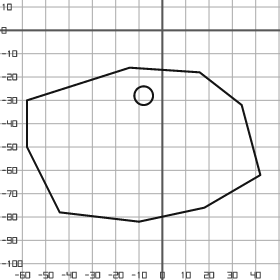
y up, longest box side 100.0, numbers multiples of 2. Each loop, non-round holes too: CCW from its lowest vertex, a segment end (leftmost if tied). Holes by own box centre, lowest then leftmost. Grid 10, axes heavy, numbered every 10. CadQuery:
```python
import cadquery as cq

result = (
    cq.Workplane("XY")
    .moveTo(-10.0, -82.0)
    .lineTo(18.0, -76.0)
    .lineTo(42.0, -62.0)
    .lineTo(34.0, -32.0)
    .lineTo(16.0, -18.0)
    .lineTo(-14.0, -16.0)
    .lineTo(-58.0, -30.0)
    .lineTo(-58.0, -50.0)
    .lineTo(-44.0, -78.0)
    .close()
    .moveTo(-8.0, -28.0)
    .circle(4.0)
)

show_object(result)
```